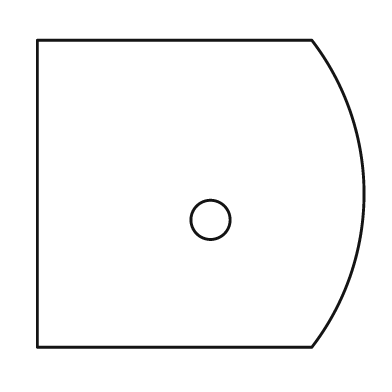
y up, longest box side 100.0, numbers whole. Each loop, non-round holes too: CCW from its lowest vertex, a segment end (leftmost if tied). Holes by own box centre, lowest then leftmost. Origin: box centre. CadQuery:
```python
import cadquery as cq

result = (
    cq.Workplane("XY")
    .moveTo(-50.0, -47.0)
    .lineTo(34.0, -47.0)
    .threePointArc((50.0, 0.0), (34.0, 47.0))
    .lineTo(-50.0, 47.0)
    .close()
    .moveTo(3.0, -8.0)
    .circle(6.0)
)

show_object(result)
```